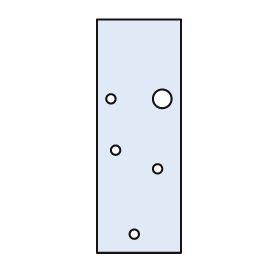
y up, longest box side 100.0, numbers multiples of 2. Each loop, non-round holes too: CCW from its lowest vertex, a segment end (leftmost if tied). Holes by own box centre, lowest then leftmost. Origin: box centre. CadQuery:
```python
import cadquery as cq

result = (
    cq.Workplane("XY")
    .moveTo(-18.0, -50.0)
    .lineTo(18.0, -50.0)
    .lineTo(18.0, 50.0)
    .lineTo(-18.0, 50.0)
    .close()
    .moveTo(-2.0, -42.0)
    .circle(2.0)
    .moveTo(8.0, -14.0)
    .circle(2.0)
    .moveTo(-10.0, -6.0)
    .circle(2.0)
    .moveTo(-12.0, 16.0)
    .circle(2.0)
    .moveTo(10.0, 16.0)
    .circle(4.0)
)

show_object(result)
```